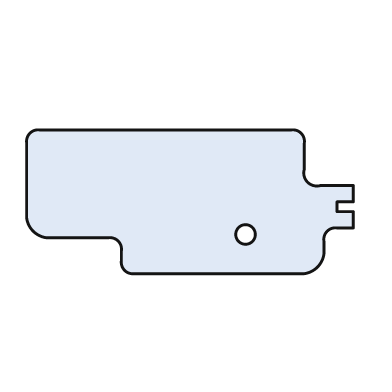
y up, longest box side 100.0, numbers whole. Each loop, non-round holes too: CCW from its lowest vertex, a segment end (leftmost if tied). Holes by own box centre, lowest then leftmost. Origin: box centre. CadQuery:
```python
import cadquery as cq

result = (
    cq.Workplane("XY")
    .moveTo(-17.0, -22.0)
    .lineTo(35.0, -22.0)
    .threePointArc((39.0, -20.0), (41.0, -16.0))
    .lineTo(41.0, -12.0)
    .threePointArc((42.0, -9.0), (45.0, -8.0))
    .lineTo(50.0, -8.0)
    .lineTo(50.0, -3.0)
    .lineTo(45.0, -3.0)
    .lineTo(45.0, 0.0)
    .lineTo(50.0, 0.0)
    .lineTo(50.0, 5.0)
    .lineTo(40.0, 5.0)
    .threePointArc((36.0, 6.0), (35.0, 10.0))
    .lineTo(35.0, 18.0)
    .threePointArc((34.0, 21.0), (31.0, 22.0))
    .lineTo(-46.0, 22.0)
    .threePointArc((-49.0, 21.0), (-50.0, 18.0))
    .lineTo(-50.0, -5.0)
    .threePointArc((-48.0, -9.0), (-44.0, -11.0))
    .lineTo(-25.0, -11.0)
    .threePointArc((-22.0, -12.0), (-21.0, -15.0))
    .lineTo(-21.0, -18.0)
    .threePointArc((-20.0, -21.0), (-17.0, -22.0))
    .close()
    .moveTo(17.0, -10.0)
    .circle(3.0)
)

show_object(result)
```